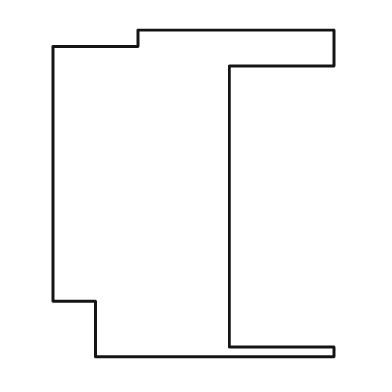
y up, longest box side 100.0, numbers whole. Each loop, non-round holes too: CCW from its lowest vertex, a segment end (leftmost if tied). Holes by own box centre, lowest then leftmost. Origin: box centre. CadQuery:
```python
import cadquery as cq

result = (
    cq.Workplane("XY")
    .moveTo(-30.0, -50.0)
    .lineTo(43.0, -50.0)
    .lineTo(43.0, -47.0)
    .lineTo(11.0, -47.0)
    .lineTo(11.0, 39.0)
    .lineTo(43.0, 39.0)
    .lineTo(43.0, 50.0)
    .lineTo(-17.0, 50.0)
    .lineTo(-17.0, 45.0)
    .lineTo(-43.0, 45.0)
    .lineTo(-43.0, -33.0)
    .lineTo(-30.0, -33.0)
    .close()
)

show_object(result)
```